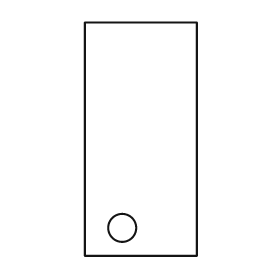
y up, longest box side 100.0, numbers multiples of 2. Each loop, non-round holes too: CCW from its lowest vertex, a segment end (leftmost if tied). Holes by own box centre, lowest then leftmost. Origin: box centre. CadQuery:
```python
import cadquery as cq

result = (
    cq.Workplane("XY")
    .moveTo(-24.0, -50.0)
    .lineTo(24.0, -50.0)
    .lineTo(24.0, 50.0)
    .lineTo(-24.0, 50.0)
    .close()
    .moveTo(-8.0, -38.0)
    .circle(6.0)
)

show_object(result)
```